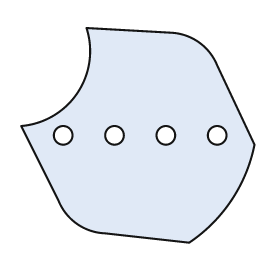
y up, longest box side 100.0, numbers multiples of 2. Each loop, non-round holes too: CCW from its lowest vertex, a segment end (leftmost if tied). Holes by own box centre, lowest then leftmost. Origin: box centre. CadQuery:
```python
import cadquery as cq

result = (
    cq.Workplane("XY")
    .moveTo(22.0, -46.0)
    .threePointArc((40.0, -28.0), (50.0, -4.0))
    .lineTo(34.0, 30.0)
    .threePointArc((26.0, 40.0), (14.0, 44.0))
    .lineTo(-22.0, 46.0)
    .threePointArc((-26.0, 18.0), (-50.0, 4.0))
    .lineTo(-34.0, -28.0)
    .threePointArc((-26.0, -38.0), (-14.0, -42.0))
    .close()
    .moveTo(-32.0, 0.0)
    .circle(4.0)
    .moveTo(-10.0, 0.0)
    .circle(4.0)
    .moveTo(12.0, 0.0)
    .circle(4.0)
    .moveTo(34.0, 0.0)
    .circle(4.0)
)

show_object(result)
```